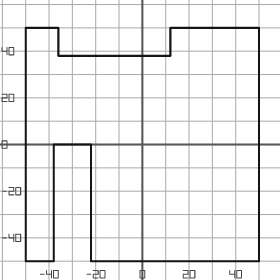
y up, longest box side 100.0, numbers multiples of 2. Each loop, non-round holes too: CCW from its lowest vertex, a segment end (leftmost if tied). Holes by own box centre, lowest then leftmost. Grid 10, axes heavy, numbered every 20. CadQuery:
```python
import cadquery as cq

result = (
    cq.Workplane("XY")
    .moveTo(-50.0, -50.0)
    .lineTo(-38.0, -50.0)
    .lineTo(-38.0, 0.0)
    .lineTo(-22.0, 0.0)
    .lineTo(-22.0, -50.0)
    .lineTo(50.0, -50.0)
    .lineTo(50.0, 50.0)
    .lineTo(12.0, 50.0)
    .lineTo(12.0, 38.0)
    .lineTo(-36.0, 38.0)
    .lineTo(-36.0, 50.0)
    .lineTo(-50.0, 50.0)
    .close()
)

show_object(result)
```